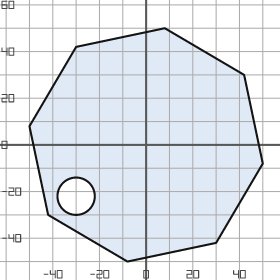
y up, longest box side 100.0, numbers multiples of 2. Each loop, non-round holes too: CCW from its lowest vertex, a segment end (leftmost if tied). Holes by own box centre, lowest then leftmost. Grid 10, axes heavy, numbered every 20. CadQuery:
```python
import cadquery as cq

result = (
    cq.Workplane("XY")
    .moveTo(-8.0, -50.0)
    .lineTo(30.0, -42.0)
    .lineTo(50.0, -8.0)
    .lineTo(42.0, 30.0)
    .lineTo(8.0, 50.0)
    .lineTo(-30.0, 42.0)
    .lineTo(-50.0, 8.0)
    .lineTo(-42.0, -30.0)
    .close()
    .moveTo(-30.0, -22.0)
    .circle(8.0)
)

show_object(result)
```